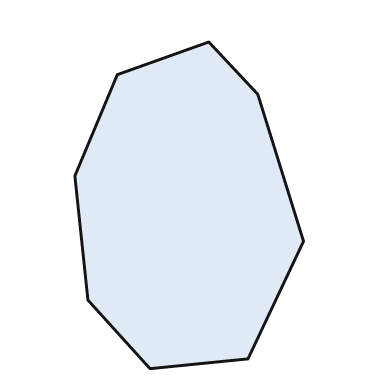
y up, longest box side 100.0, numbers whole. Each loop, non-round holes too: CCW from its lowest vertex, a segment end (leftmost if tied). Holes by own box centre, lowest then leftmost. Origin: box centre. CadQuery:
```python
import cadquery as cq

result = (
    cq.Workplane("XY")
    .moveTo(-12.0, -50.0)
    .lineTo(18.0, -47.0)
    .lineTo(35.0, -11.0)
    .lineTo(21.0, 34.0)
    .lineTo(6.0, 50.0)
    .lineTo(-22.0, 40.0)
    .lineTo(-35.0, 9.0)
    .lineTo(-31.0, -29.0)
    .close()
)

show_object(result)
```